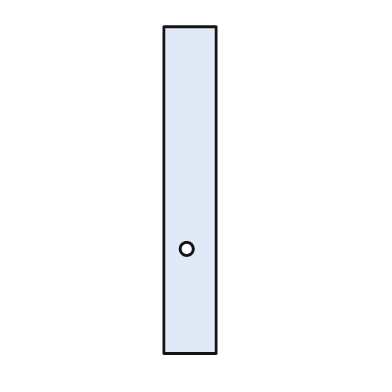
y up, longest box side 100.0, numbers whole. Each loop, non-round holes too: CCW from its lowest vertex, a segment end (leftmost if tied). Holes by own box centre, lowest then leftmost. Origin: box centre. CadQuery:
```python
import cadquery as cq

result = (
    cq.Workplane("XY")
    .moveTo(-8.0, -50.0)
    .lineTo(8.0, -50.0)
    .lineTo(8.0, 50.0)
    .lineTo(-8.0, 50.0)
    .close()
    .moveTo(-1.0, -18.0)
    .circle(2.0)
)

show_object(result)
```